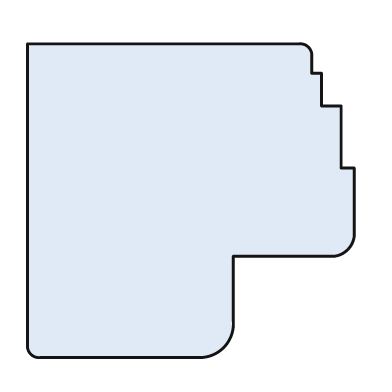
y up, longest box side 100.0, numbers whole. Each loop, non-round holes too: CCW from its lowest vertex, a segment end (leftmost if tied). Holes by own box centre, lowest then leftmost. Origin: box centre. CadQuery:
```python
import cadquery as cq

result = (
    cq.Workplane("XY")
    .moveTo(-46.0, -48.0)
    .lineTo(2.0, -48.0)
    .threePointArc((10.0, -45.0), (13.0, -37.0))
    .lineTo(13.0, -17.0)
    .lineTo(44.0, -17.0)
    .threePointArc((48.0, -15.0), (50.0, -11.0))
    .lineTo(50.0, 10.0)
    .lineTo(46.0, 10.0)
    .lineTo(46.0, 29.0)
    .lineTo(40.0, 29.0)
    .lineTo(40.0, 39.0)
    .lineTo(37.0, 39.0)
    .lineTo(37.0, 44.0)
    .threePointArc((36.0, 47.0), (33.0, 48.0))
    .lineTo(-50.0, 48.0)
    .lineTo(-50.0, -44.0)
    .threePointArc((-49.0, -47.0), (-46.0, -48.0))
    .close()
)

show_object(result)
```